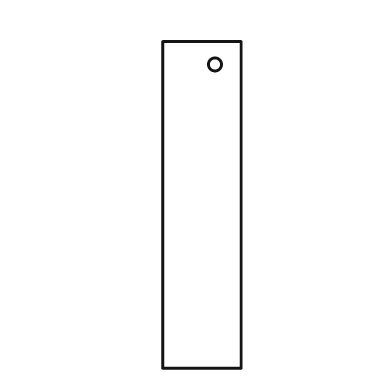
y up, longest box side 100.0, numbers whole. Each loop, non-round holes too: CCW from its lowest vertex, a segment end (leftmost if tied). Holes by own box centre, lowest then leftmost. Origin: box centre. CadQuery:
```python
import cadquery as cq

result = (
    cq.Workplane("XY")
    .moveTo(-12.0, -50.0)
    .lineTo(12.0, -50.0)
    .lineTo(12.0, 50.0)
    .lineTo(-12.0, 50.0)
    .close()
    .moveTo(4.0, 43.0)
    .circle(2.0)
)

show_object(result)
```